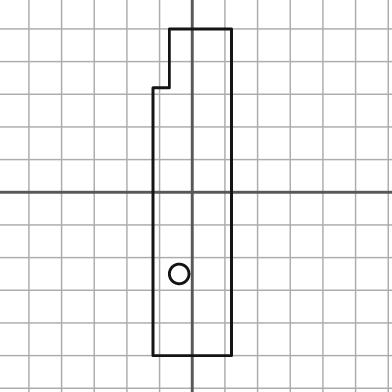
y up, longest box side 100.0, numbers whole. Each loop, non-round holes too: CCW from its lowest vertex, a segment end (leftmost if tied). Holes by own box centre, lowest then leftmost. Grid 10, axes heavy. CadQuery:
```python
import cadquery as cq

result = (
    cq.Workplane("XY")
    .moveTo(-12.0, -50.0)
    .lineTo(12.0, -50.0)
    .lineTo(12.0, 50.0)
    .lineTo(-7.0, 50.0)
    .lineTo(-7.0, 32.0)
    .lineTo(-12.0, 32.0)
    .close()
    .moveTo(-4.0, -25.0)
    .circle(3.0)
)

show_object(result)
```